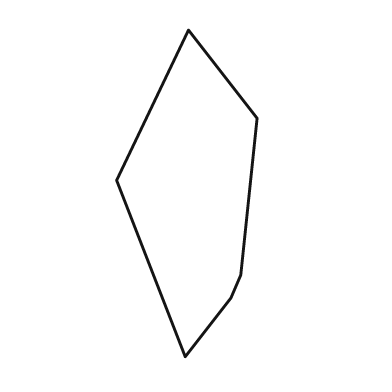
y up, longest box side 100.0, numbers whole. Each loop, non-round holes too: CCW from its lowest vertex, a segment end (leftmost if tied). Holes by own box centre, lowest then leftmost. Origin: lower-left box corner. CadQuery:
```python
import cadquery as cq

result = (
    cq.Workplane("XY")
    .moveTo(21.0, 0.0)
    .lineTo(35.0, 18.0)
    .lineTo(38.0, 25.0)
    .lineTo(43.0, 73.0)
    .lineTo(22.0, 100.0)
    .lineTo(0.0, 54.0)
    .close()
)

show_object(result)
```